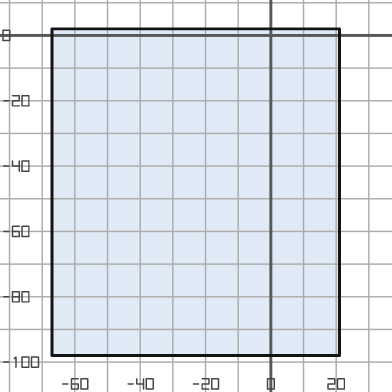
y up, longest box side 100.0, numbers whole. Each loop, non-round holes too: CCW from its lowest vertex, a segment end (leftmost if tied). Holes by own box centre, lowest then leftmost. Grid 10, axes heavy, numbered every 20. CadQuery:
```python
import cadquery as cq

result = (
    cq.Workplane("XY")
    .moveTo(-67.0, -98.0)
    .lineTo(21.0, -98.0)
    .lineTo(21.0, 2.0)
    .lineTo(-67.0, 2.0)
    .close()
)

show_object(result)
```